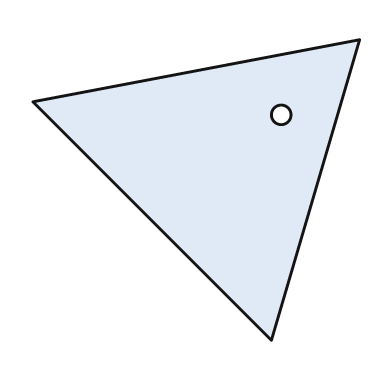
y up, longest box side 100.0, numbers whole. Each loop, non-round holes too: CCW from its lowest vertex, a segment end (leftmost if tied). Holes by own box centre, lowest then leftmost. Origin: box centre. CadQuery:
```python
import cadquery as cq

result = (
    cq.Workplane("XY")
    .moveTo(23.0, -46.0)
    .lineTo(50.0, 46.0)
    .lineTo(-50.0, 27.0)
    .close()
    .moveTo(26.0, 23.0)
    .circle(3.0)
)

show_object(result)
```